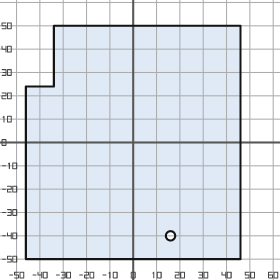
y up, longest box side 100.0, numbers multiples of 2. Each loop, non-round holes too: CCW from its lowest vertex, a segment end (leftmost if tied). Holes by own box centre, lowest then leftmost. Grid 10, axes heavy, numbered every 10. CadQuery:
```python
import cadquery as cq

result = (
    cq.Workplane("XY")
    .moveTo(-46.0, -50.0)
    .lineTo(46.0, -50.0)
    .lineTo(46.0, 50.0)
    .lineTo(-34.0, 50.0)
    .lineTo(-34.0, 24.0)
    .lineTo(-46.0, 24.0)
    .close()
    .moveTo(16.0, -40.0)
    .circle(2.0)
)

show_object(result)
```